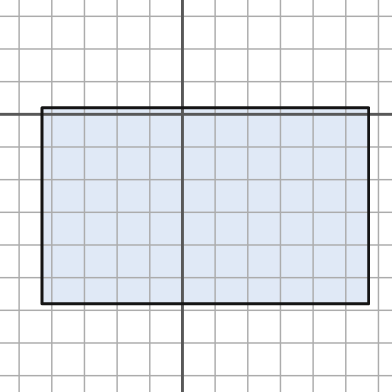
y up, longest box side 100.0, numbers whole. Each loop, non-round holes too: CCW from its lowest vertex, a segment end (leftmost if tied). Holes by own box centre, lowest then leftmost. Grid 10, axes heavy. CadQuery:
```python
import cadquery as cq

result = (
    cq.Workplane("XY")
    .moveTo(-43.0, -58.0)
    .lineTo(57.0, -58.0)
    .lineTo(57.0, 2.0)
    .lineTo(-43.0, 2.0)
    .close()
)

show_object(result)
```